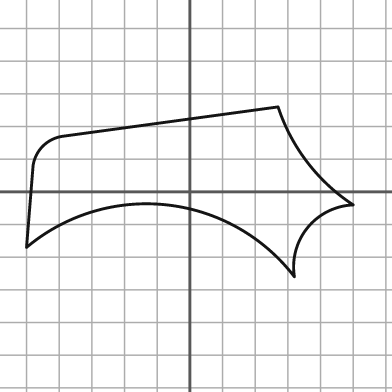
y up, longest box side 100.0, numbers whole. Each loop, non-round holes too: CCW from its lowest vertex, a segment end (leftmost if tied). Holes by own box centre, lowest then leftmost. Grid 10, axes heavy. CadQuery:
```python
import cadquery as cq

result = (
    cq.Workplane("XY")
    .moveTo(32.0, -26.0)
    .threePointArc((36.0, -11.0), (50.0, -4.0))
    .threePointArc((36.0, 9.0), (27.0, 26.0))
    .lineTo(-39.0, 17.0)
    .threePointArc((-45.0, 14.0), (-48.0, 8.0))
    .lineTo(-50.0, -17.0)
    .threePointArc((-7.0, -4.0), (32.0, -26.0))
    .close()
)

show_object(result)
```